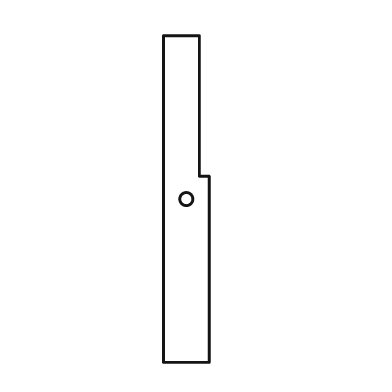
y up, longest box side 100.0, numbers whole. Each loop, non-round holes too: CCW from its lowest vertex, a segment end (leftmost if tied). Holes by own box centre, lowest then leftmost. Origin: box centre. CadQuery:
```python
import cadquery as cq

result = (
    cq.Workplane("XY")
    .moveTo(-7.0, -50.0)
    .lineTo(7.0, -50.0)
    .lineTo(7.0, 7.0)
    .lineTo(4.0, 7.0)
    .lineTo(4.0, 50.0)
    .lineTo(-7.0, 50.0)
    .close()
    .moveTo(0.0, 0.0)
    .circle(2.0)
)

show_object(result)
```